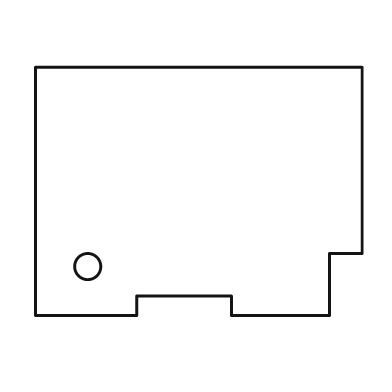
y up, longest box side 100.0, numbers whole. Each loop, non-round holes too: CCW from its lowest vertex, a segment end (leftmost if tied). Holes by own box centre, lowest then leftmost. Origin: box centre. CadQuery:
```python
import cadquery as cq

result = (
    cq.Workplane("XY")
    .moveTo(-50.0, -38.0)
    .lineTo(-19.0, -38.0)
    .lineTo(-19.0, -32.0)
    .lineTo(10.0, -32.0)
    .lineTo(10.0, -38.0)
    .lineTo(40.0, -38.0)
    .lineTo(40.0, -19.0)
    .lineTo(50.0, -19.0)
    .lineTo(50.0, 38.0)
    .lineTo(-50.0, 38.0)
    .close()
    .moveTo(-34.0, -23.0)
    .circle(4.0)
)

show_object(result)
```